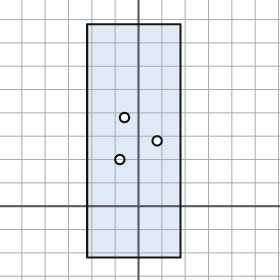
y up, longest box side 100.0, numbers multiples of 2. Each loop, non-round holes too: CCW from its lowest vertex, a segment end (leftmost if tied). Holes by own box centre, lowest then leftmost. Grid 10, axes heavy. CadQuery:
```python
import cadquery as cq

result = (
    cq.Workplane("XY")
    .moveTo(-22.0, -22.0)
    .lineTo(18.0, -22.0)
    .lineTo(18.0, 78.0)
    .lineTo(-22.0, 78.0)
    .close()
    .moveTo(-8.0, 20.0)
    .circle(2.0)
    .moveTo(8.0, 28.0)
    .circle(2.0)
    .moveTo(-6.0, 38.0)
    .circle(2.0)
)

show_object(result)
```